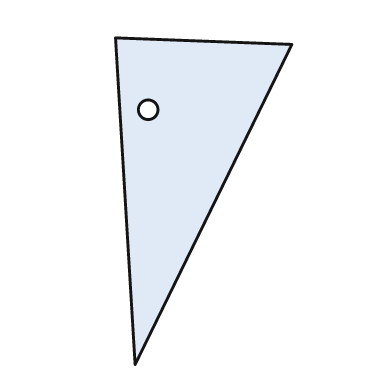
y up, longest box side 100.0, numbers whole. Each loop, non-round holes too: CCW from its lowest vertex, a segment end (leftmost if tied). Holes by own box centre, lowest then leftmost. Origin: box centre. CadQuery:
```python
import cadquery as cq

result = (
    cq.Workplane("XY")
    .moveTo(-21.0, -50.0)
    .lineTo(27.0, 48.0)
    .lineTo(-27.0, 50.0)
    .close()
    .moveTo(-17.0, 28.0)
    .circle(3.0)
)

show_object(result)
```